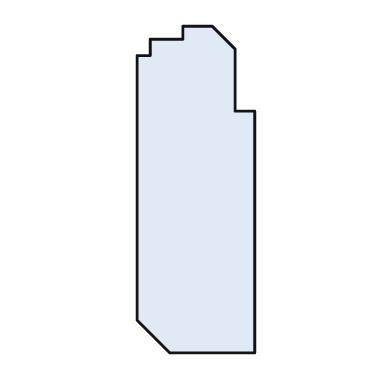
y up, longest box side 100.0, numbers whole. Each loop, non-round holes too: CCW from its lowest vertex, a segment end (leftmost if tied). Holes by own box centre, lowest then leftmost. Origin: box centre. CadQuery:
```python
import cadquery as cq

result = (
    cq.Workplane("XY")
    .moveTo(-8.0, -50.0)
    .lineTo(18.0, -50.0)
    .lineTo(18.0, 24.0)
    .lineTo(12.0, 24.0)
    .lineTo(12.0, 43.0)
    .lineTo(5.0, 50.0)
    .lineTo(-4.0, 50.0)
    .lineTo(-4.0, 46.0)
    .lineTo(-14.0, 46.0)
    .lineTo(-14.0, 41.0)
    .lineTo(-18.0, 41.0)
    .lineTo(-18.0, -40.0)
    .close()
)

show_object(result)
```